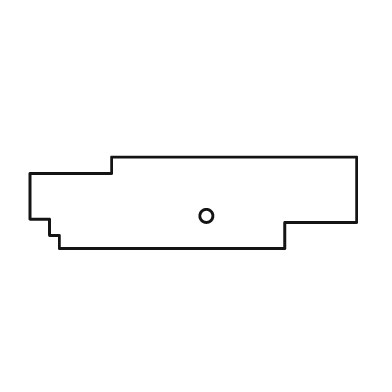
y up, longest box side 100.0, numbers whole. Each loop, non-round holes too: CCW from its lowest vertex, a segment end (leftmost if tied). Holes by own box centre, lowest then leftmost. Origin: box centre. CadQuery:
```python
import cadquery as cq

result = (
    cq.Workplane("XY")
    .moveTo(-41.0, -14.0)
    .lineTo(28.0, -14.0)
    .lineTo(28.0, -6.0)
    .lineTo(50.0, -6.0)
    .lineTo(50.0, 14.0)
    .lineTo(-25.0, 14.0)
    .lineTo(-25.0, 9.0)
    .lineTo(-50.0, 9.0)
    .lineTo(-50.0, -5.0)
    .lineTo(-44.0, -5.0)
    .lineTo(-44.0, -10.0)
    .lineTo(-41.0, -10.0)
    .close()
    .moveTo(4.0, -4.0)
    .circle(2.0)
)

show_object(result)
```